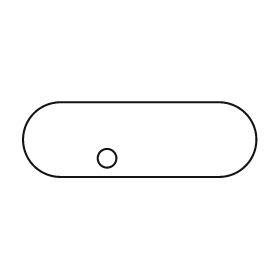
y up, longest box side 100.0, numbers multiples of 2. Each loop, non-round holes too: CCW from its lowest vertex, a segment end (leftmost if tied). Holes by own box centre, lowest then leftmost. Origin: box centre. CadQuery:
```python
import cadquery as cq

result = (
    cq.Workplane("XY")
    .moveTo(-34.0, -16.0)
    .lineTo(34.0, -16.0)
    .threePointArc((50.0, 0.0), (34.0, 16.0))
    .lineTo(-34.0, 16.0)
    .threePointArc((-50.0, 0.0), (-34.0, -16.0))
    .close()
    .moveTo(-14.0, -8.0)
    .circle(4.0)
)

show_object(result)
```